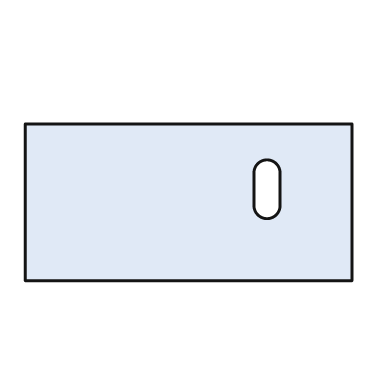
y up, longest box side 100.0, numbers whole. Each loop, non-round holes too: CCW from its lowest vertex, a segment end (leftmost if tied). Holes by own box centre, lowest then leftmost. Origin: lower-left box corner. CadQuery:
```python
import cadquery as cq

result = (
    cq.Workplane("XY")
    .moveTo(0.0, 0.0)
    .lineTo(100.0, 0.0)
    .lineTo(100.0, 48.0)
    .lineTo(0.0, 48.0)
    .close()
    .moveTo(70.0, 23.0)
    .threePointArc((74.0, 19.0), (78.0, 23.0))
    .lineTo(78.0, 33.0)
    .threePointArc((74.0, 37.0), (70.0, 33.0))
    .close()
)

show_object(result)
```